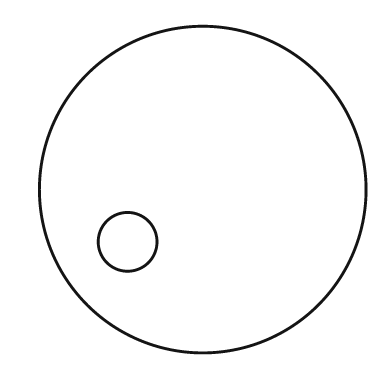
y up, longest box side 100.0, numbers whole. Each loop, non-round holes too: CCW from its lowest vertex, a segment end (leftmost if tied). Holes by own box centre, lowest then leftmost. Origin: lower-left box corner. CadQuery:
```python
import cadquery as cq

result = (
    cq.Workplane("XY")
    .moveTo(50.0, 50.0)
    .circle(50.0)
    .moveTo(27.0, 34.0)
    .circle(9.0)
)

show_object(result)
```